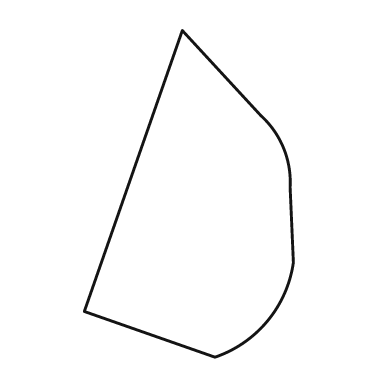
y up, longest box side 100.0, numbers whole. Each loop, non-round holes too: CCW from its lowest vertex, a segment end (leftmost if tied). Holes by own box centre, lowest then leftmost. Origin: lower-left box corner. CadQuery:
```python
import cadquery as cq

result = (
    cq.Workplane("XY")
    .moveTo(40.0, 0.0)
    .threePointArc((56.0, 11.0), (64.0, 29.0))
    .lineTo(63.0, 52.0)
    .threePointArc((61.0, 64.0), (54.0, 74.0))
    .lineTo(30.0, 100.0)
    .lineTo(0.0, 14.0)
    .close()
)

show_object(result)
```